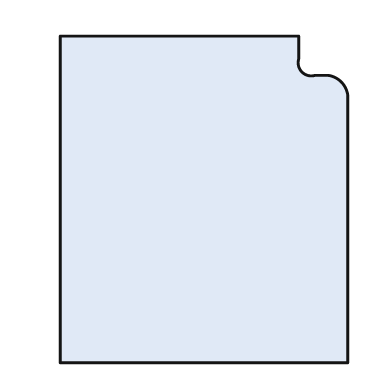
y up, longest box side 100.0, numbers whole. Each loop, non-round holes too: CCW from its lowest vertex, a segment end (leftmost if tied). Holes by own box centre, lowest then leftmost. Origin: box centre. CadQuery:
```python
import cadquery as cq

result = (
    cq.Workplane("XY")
    .moveTo(-44.0, -50.0)
    .lineTo(44.0, -50.0)
    .lineTo(44.0, 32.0)
    .threePointArc((42.0, 36.0), (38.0, 38.0))
    .lineTo(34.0, 38.0)
    .threePointArc((30.0, 39.0), (29.0, 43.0))
    .lineTo(29.0, 50.0)
    .lineTo(-44.0, 50.0)
    .close()
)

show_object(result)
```